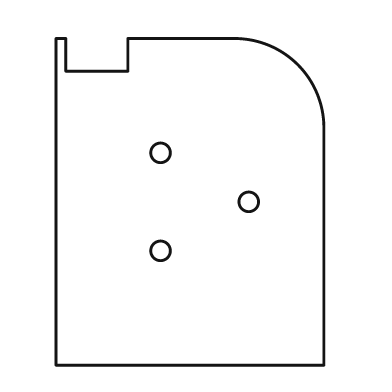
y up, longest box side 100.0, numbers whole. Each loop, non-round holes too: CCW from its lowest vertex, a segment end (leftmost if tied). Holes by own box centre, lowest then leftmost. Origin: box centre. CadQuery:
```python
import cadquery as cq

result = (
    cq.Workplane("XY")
    .moveTo(-41.0, -50.0)
    .lineTo(41.0, -50.0)
    .lineTo(41.0, 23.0)
    .threePointArc((33.0, 42.0), (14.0, 50.0))
    .lineTo(-19.0, 50.0)
    .lineTo(-19.0, 40.0)
    .lineTo(-38.0, 40.0)
    .lineTo(-38.0, 50.0)
    .lineTo(-41.0, 50.0)
    .close()
    .moveTo(-9.0, -15.0)
    .circle(3.0)
    .moveTo(18.0, 0.0)
    .circle(3.0)
    .moveTo(-9.0, 15.0)
    .circle(3.0)
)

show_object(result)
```